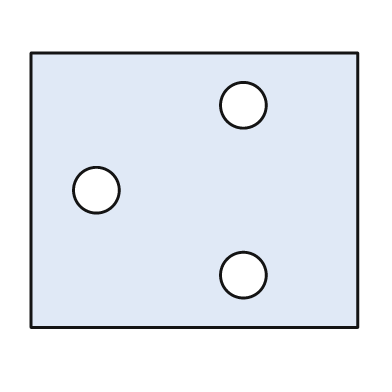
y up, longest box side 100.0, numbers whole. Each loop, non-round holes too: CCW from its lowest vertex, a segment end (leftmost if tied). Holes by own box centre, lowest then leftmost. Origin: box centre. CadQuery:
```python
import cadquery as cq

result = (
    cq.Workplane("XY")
    .moveTo(-50.0, -42.0)
    .lineTo(50.0, -42.0)
    .lineTo(50.0, 42.0)
    .lineTo(-50.0, 42.0)
    .close()
    .moveTo(15.0, -26.0)
    .circle(7.0)
    .moveTo(-30.0, 0.0)
    .circle(7.0)
    .moveTo(15.0, 26.0)
    .circle(7.0)
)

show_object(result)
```